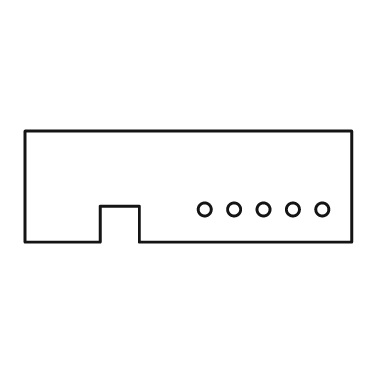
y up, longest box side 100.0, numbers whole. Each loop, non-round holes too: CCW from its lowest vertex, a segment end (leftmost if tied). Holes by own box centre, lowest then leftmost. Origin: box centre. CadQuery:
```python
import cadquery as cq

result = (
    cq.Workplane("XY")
    .moveTo(-50.0, -17.0)
    .lineTo(-27.0, -17.0)
    .lineTo(-27.0, -6.0)
    .lineTo(-15.0, -6.0)
    .lineTo(-15.0, -17.0)
    .lineTo(50.0, -17.0)
    .lineTo(50.0, 17.0)
    .lineTo(-50.0, 17.0)
    .close()
    .moveTo(5.0, -7.0)
    .circle(2.0)
    .moveTo(14.0, -7.0)
    .circle(2.0)
    .moveTo(23.0, -7.0)
    .circle(2.0)
    .moveTo(32.0, -7.0)
    .circle(2.0)
    .moveTo(41.0, -7.0)
    .circle(2.0)
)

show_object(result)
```